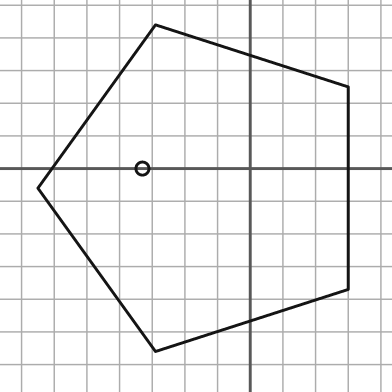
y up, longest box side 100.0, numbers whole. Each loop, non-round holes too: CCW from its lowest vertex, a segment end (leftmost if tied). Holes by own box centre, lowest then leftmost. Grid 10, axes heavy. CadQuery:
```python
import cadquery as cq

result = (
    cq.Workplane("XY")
    .moveTo(-29.0, -56.0)
    .lineTo(30.0, -37.0)
    .lineTo(30.0, 25.0)
    .lineTo(-29.0, 44.0)
    .lineTo(-65.0, -6.0)
    .close()
    .moveTo(-33.0, 0.0)
    .circle(2.0)
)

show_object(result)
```